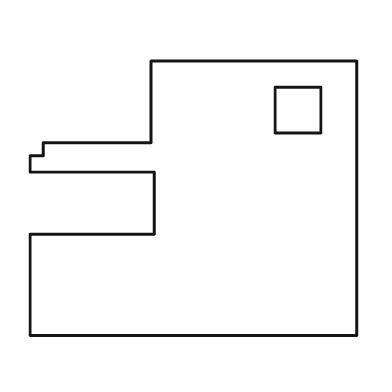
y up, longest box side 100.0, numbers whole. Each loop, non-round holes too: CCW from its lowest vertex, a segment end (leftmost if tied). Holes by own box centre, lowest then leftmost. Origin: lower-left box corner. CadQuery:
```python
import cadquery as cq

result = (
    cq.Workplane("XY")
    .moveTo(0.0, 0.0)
    .lineTo(100.0, 0.0)
    .lineTo(100.0, 84.0)
    .lineTo(37.0, 84.0)
    .lineTo(37.0, 59.0)
    .lineTo(4.0, 59.0)
    .lineTo(4.0, 55.0)
    .lineTo(0.0, 55.0)
    .lineTo(0.0, 50.0)
    .lineTo(38.0, 50.0)
    .lineTo(38.0, 31.0)
    .lineTo(0.0, 31.0)
    .close()
    .moveTo(75.0, 62.0)
    .lineTo(89.0, 62.0)
    .lineTo(89.0, 76.0)
    .lineTo(75.0, 76.0)
    .close()
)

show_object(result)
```